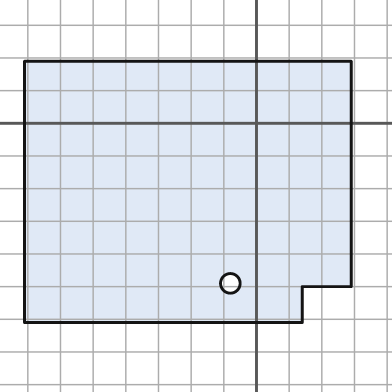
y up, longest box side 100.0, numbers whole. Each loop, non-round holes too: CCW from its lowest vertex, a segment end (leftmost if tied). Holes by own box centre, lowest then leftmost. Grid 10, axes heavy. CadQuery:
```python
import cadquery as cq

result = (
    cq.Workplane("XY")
    .moveTo(-71.0, -61.0)
    .lineTo(14.0, -61.0)
    .lineTo(14.0, -50.0)
    .lineTo(29.0, -50.0)
    .lineTo(29.0, 19.0)
    .lineTo(-71.0, 19.0)
    .close()
    .moveTo(-8.0, -49.0)
    .circle(3.0)
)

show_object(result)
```